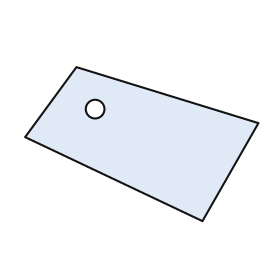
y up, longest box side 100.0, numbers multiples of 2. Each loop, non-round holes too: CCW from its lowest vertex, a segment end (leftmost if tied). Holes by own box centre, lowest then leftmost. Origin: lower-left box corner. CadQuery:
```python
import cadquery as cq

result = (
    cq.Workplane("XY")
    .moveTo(76.0, 0.0)
    .lineTo(100.0, 42.0)
    .lineTo(22.0, 66.0)
    .lineTo(0.0, 36.0)
    .close()
    .moveTo(30.0, 48.0)
    .circle(4.0)
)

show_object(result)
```